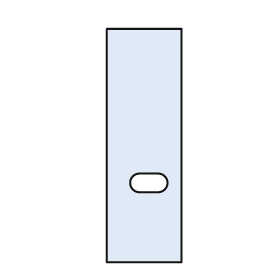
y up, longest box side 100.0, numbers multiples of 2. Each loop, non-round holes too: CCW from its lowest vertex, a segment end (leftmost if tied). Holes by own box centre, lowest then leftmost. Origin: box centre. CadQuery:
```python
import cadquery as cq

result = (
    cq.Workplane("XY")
    .moveTo(-16.0, -50.0)
    .lineTo(16.0, -50.0)
    .lineTo(16.0, 50.0)
    .lineTo(-16.0, 50.0)
    .close()
    .moveTo(-2.0, -20.0)
    .lineTo(6.0, -20.0)
    .threePointArc((10.0, -16.0), (6.0, -12.0))
    .lineTo(-2.0, -12.0)
    .threePointArc((-6.0, -16.0), (-2.0, -20.0))
    .close()
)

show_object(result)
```